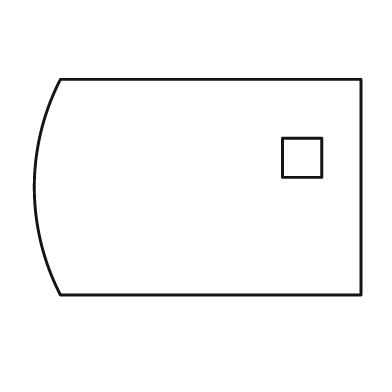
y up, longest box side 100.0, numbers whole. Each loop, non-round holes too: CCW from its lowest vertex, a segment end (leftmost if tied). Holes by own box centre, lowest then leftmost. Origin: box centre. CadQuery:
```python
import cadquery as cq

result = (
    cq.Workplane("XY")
    .moveTo(-42.0, -33.0)
    .lineTo(50.0, -33.0)
    .lineTo(50.0, 33.0)
    .lineTo(-42.0, 33.0)
    .threePointArc((-50.0, 0.0), (-42.0, -33.0))
    .close()
    .moveTo(26.0, 3.0)
    .lineTo(38.0, 3.0)
    .lineTo(38.0, 15.0)
    .lineTo(26.0, 15.0)
    .close()
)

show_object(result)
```